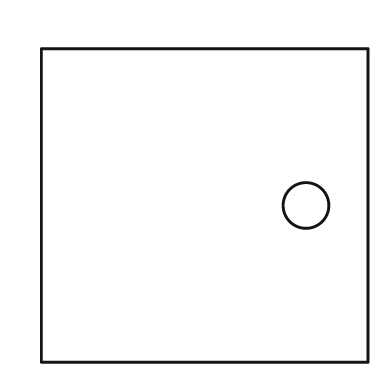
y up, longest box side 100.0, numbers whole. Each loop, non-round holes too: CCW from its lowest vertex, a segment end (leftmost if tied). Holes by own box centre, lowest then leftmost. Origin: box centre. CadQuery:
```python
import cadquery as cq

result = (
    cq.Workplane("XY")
    .moveTo(-50.0, -48.0)
    .lineTo(50.0, -48.0)
    .lineTo(50.0, 48.0)
    .lineTo(-50.0, 48.0)
    .close()
    .moveTo(31.0, 0.0)
    .circle(7.0)
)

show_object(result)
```